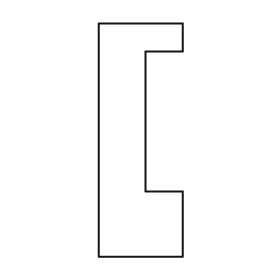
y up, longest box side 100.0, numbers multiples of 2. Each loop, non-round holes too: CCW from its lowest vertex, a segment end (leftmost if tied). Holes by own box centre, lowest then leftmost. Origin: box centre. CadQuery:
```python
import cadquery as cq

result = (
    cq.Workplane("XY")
    .moveTo(-18.0, -50.0)
    .lineTo(18.0, -50.0)
    .lineTo(18.0, -22.0)
    .lineTo(2.0, -22.0)
    .lineTo(2.0, 38.0)
    .lineTo(18.0, 38.0)
    .lineTo(18.0, 50.0)
    .lineTo(-18.0, 50.0)
    .close()
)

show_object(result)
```